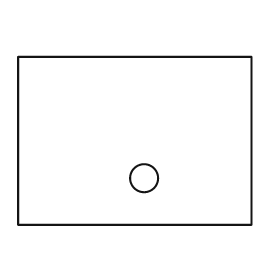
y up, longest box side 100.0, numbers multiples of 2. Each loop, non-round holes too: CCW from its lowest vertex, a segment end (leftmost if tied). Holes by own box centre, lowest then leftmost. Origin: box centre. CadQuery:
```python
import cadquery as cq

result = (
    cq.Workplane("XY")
    .moveTo(-50.0, -36.0)
    .lineTo(50.0, -36.0)
    .lineTo(50.0, 36.0)
    .lineTo(-50.0, 36.0)
    .close()
    .moveTo(4.0, -16.0)
    .circle(6.0)
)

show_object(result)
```